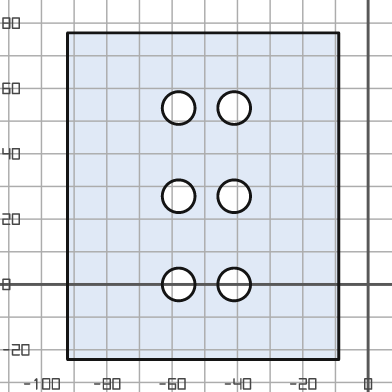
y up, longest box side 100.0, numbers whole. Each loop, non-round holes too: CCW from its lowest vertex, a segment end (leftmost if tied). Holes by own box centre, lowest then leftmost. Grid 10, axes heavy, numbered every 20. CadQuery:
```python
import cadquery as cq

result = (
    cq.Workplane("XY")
    .moveTo(-92.0, -23.0)
    .lineTo(-9.0, -23.0)
    .lineTo(-9.0, 77.0)
    .lineTo(-92.0, 77.0)
    .close()
    .moveTo(-58.0, 0.0)
    .circle(5.0)
    .moveTo(-41.0, 0.0)
    .circle(5.0)
    .moveTo(-58.0, 27.0)
    .circle(5.0)
    .moveTo(-41.0, 27.0)
    .circle(5.0)
    .moveTo(-58.0, 54.0)
    .circle(5.0)
    .moveTo(-41.0, 54.0)
    .circle(5.0)
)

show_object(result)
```